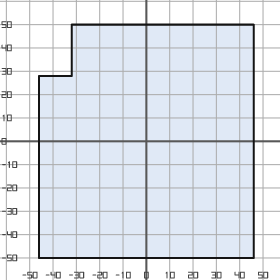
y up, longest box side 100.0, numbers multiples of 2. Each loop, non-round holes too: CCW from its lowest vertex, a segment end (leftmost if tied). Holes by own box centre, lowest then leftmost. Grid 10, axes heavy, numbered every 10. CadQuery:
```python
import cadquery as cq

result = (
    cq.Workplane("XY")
    .moveTo(-46.0, -50.0)
    .lineTo(46.0, -50.0)
    .lineTo(46.0, 50.0)
    .lineTo(-32.0, 50.0)
    .lineTo(-32.0, 28.0)
    .lineTo(-46.0, 28.0)
    .close()
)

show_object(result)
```